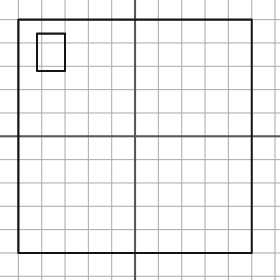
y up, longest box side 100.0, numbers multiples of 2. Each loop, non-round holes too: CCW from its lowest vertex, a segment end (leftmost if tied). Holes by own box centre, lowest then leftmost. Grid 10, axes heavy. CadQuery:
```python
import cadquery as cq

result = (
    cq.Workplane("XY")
    .moveTo(-50.0, -50.0)
    .lineTo(50.0, -50.0)
    .lineTo(50.0, 50.0)
    .lineTo(-50.0, 50.0)
    .close()
    .moveTo(-42.0, 28.0)
    .lineTo(-30.0, 28.0)
    .lineTo(-30.0, 44.0)
    .lineTo(-42.0, 44.0)
    .close()
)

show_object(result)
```